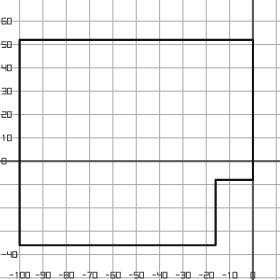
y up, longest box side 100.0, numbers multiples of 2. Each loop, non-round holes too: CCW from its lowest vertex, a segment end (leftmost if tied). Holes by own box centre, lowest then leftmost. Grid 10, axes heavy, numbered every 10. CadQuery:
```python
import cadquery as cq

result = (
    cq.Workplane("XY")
    .moveTo(-100.0, -36.0)
    .lineTo(-16.0, -36.0)
    .lineTo(-16.0, -8.0)
    .lineTo(0.0, -8.0)
    .lineTo(0.0, 52.0)
    .lineTo(-100.0, 52.0)
    .close()
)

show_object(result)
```